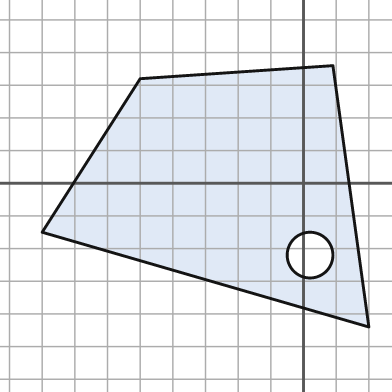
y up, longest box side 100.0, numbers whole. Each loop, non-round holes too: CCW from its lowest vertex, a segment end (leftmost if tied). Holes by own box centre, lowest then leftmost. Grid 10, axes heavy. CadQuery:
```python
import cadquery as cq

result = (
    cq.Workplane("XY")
    .moveTo(20.0, -44.0)
    .lineTo(9.0, 36.0)
    .lineTo(-50.0, 32.0)
    .lineTo(-80.0, -15.0)
    .close()
    .moveTo(2.0, -22.0)
    .circle(7.0)
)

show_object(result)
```